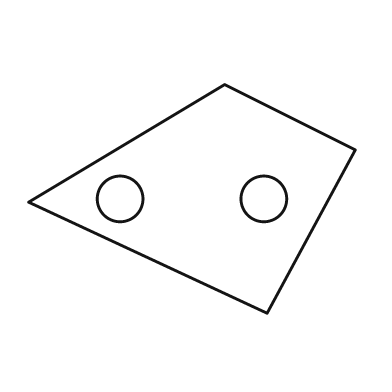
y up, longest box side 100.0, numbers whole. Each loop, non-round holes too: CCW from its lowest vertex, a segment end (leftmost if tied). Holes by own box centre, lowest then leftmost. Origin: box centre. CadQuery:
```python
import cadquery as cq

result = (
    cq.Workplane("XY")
    .moveTo(23.0, -35.0)
    .lineTo(50.0, 15.0)
    .lineTo(10.0, 35.0)
    .lineTo(-50.0, -1.0)
    .close()
    .moveTo(-22.0, 0.0)
    .circle(7.0)
    .moveTo(22.0, 0.0)
    .circle(7.0)
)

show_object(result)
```